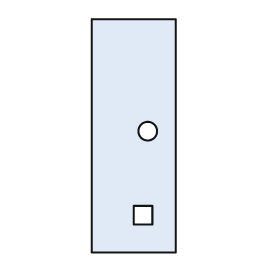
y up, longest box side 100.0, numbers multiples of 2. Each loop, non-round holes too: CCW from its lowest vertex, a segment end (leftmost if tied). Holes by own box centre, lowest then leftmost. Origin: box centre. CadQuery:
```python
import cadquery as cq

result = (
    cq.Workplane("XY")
    .moveTo(-18.0, -50.0)
    .lineTo(18.0, -50.0)
    .lineTo(18.0, 50.0)
    .lineTo(-18.0, 50.0)
    .close()
    .moveTo(0.0, -38.0)
    .lineTo(8.0, -38.0)
    .lineTo(8.0, -30.0)
    .lineTo(0.0, -30.0)
    .close()
    .moveTo(6.0, 2.0)
    .circle(4.0)
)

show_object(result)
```